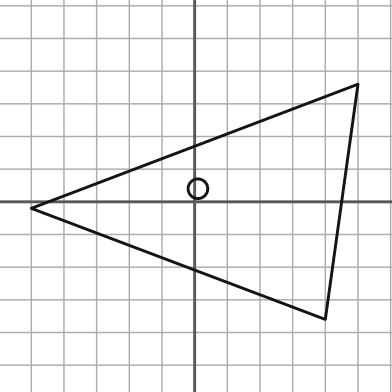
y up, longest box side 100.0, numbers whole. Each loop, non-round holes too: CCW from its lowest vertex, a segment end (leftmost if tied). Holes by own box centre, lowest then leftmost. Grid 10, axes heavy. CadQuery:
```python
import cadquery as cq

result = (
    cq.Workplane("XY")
    .moveTo(40.0, -36.0)
    .lineTo(50.0, 36.0)
    .lineTo(-50.0, -2.0)
    .close()
    .moveTo(1.0, 4.0)
    .circle(3.0)
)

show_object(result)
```